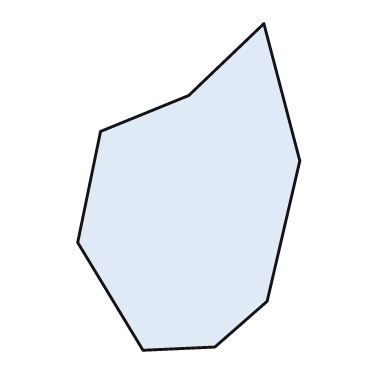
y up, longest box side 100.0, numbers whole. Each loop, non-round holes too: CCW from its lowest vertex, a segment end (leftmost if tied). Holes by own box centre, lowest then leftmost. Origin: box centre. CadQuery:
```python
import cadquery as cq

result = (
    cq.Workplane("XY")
    .moveTo(-14.0, -50.0)
    .lineTo(8.0, -49.0)
    .lineTo(24.0, -35.0)
    .lineTo(34.0, 8.0)
    .lineTo(23.0, 50.0)
    .lineTo(0.0, 28.0)
    .lineTo(-27.0, 17.0)
    .lineTo(-34.0, -17.0)
    .close()
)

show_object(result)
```